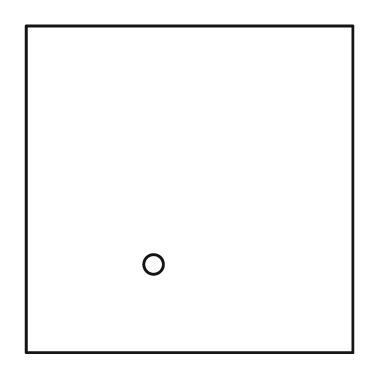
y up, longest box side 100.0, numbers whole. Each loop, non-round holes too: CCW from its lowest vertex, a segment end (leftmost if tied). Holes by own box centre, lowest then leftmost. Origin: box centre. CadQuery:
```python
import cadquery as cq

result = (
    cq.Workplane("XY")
    .moveTo(-50.0, -50.0)
    .lineTo(50.0, -50.0)
    .lineTo(50.0, 50.0)
    .lineTo(-50.0, 50.0)
    .close()
    .moveTo(-11.0, -23.0)
    .circle(3.0)
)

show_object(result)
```